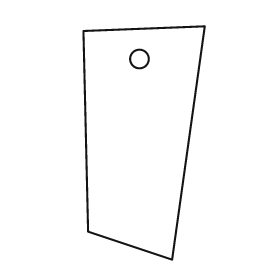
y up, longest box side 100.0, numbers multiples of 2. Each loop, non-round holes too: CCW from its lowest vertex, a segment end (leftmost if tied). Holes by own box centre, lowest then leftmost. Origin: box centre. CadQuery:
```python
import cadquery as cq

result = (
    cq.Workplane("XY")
    .moveTo(12.0, -50.0)
    .lineTo(26.0, 50.0)
    .lineTo(-26.0, 48.0)
    .lineTo(-24.0, -38.0)
    .close()
    .moveTo(-2.0, 36.0)
    .circle(4.0)
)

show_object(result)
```